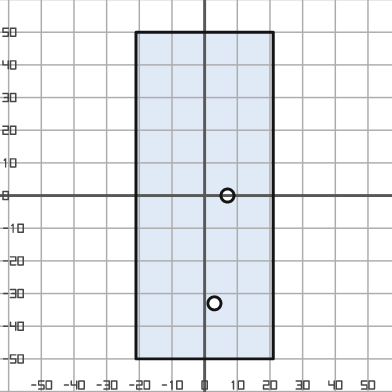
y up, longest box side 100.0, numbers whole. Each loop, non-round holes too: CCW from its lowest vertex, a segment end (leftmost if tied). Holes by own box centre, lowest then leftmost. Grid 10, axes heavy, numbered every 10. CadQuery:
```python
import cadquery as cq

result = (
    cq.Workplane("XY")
    .moveTo(-21.0, -50.0)
    .lineTo(21.0, -50.0)
    .lineTo(21.0, 50.0)
    .lineTo(-21.0, 50.0)
    .close()
    .moveTo(3.0, -33.0)
    .circle(2.0)
    .moveTo(7.0, 0.0)
    .circle(2.0)
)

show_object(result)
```